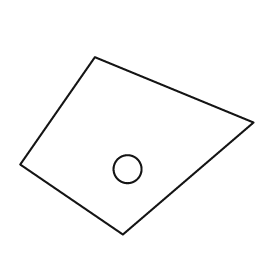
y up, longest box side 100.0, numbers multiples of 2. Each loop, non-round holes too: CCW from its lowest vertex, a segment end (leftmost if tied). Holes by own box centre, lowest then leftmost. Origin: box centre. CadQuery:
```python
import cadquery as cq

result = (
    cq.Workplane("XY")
    .moveTo(-6.0, -38.0)
    .lineTo(50.0, 10.0)
    .lineTo(-18.0, 38.0)
    .lineTo(-50.0, -8.0)
    .close()
    .moveTo(-4.0, -10.0)
    .circle(6.0)
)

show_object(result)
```